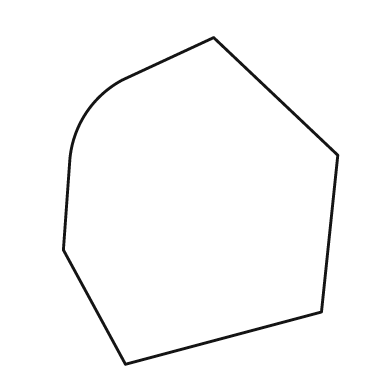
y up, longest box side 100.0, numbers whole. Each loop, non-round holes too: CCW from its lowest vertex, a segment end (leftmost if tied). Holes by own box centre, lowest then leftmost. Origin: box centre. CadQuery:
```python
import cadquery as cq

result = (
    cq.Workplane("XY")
    .moveTo(-23.0, -50.0)
    .lineTo(37.0, -34.0)
    .lineTo(42.0, 14.0)
    .lineTo(4.0, 50.0)
    .lineTo(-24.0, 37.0)
    .threePointArc((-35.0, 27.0), (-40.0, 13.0))
    .lineTo(-42.0, -15.0)
    .close()
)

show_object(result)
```